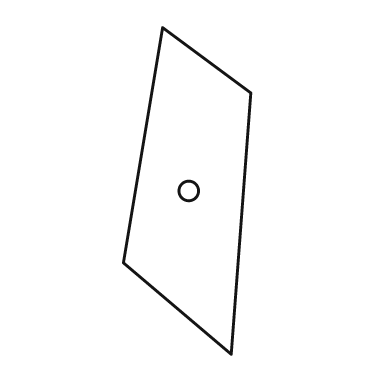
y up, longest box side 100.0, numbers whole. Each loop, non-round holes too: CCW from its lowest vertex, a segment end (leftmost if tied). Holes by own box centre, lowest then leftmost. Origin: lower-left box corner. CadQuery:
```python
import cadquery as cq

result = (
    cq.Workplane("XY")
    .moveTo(33.0, 0.0)
    .lineTo(39.0, 80.0)
    .lineTo(12.0, 100.0)
    .lineTo(0.0, 28.0)
    .close()
    .moveTo(20.0, 50.0)
    .circle(3.0)
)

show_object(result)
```